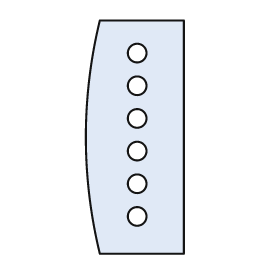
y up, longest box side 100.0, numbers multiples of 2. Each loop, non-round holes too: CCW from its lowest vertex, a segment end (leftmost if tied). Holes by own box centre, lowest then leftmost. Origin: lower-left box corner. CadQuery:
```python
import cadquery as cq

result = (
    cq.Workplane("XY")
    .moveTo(6.0, 0.0)
    .lineTo(42.0, 0.0)
    .lineTo(42.0, 100.0)
    .lineTo(6.0, 100.0)
    .threePointArc((0.0, 50.0), (6.0, 0.0))
    .close()
    .moveTo(22.0, 16.0)
    .circle(4.0)
    .moveTo(22.0, 30.0)
    .circle(4.0)
    .moveTo(22.0, 44.0)
    .circle(4.0)
    .moveTo(22.0, 58.0)
    .circle(4.0)
    .moveTo(22.0, 72.0)
    .circle(4.0)
    .moveTo(22.0, 86.0)
    .circle(4.0)
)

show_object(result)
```